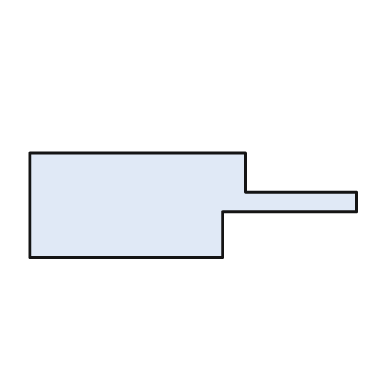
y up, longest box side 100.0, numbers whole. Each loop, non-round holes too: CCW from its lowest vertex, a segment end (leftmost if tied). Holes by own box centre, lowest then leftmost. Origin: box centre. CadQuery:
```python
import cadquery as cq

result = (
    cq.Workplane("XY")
    .moveTo(-50.0, -16.0)
    .lineTo(9.0, -16.0)
    .lineTo(9.0, -2.0)
    .lineTo(50.0, -2.0)
    .lineTo(50.0, 4.0)
    .lineTo(16.0, 4.0)
    .lineTo(16.0, 16.0)
    .lineTo(-50.0, 16.0)
    .close()
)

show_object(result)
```